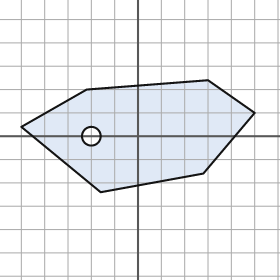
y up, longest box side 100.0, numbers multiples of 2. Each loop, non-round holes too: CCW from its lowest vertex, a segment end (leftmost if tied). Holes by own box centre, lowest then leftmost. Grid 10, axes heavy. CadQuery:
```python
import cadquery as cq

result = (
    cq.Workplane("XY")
    .moveTo(-16.0, -24.0)
    .lineTo(28.0, -16.0)
    .lineTo(50.0, 10.0)
    .lineTo(30.0, 24.0)
    .lineTo(-22.0, 20.0)
    .lineTo(-50.0, 4.0)
    .close()
    .moveTo(-20.0, 0.0)
    .circle(4.0)
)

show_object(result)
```